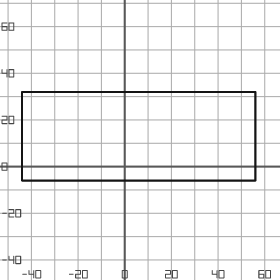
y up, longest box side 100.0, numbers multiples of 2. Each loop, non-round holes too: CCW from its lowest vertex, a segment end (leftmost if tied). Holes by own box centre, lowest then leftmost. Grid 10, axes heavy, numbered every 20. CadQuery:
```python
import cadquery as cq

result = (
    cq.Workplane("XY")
    .moveTo(-44.0, -6.0)
    .lineTo(56.0, -6.0)
    .lineTo(56.0, 32.0)
    .lineTo(-44.0, 32.0)
    .close()
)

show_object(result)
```